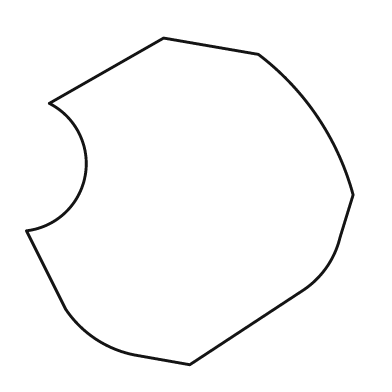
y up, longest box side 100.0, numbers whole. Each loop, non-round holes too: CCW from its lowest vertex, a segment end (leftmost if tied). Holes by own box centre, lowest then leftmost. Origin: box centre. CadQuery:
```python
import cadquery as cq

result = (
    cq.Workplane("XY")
    .moveTo(0.0, -50.0)
    .lineTo(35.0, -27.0)
    .threePointArc((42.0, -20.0), (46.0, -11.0))
    .lineTo(50.0, 2.0)
    .threePointArc((39.0, 26.0), (21.0, 45.0))
    .lineTo(-8.0, 50.0)
    .lineTo(-43.0, 30.0)
    .threePointArc((-32.0, 8.0), (-50.0, -9.0))
    .lineTo(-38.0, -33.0)
    .threePointArc((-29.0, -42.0), (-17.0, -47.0))
    .close()
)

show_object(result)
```